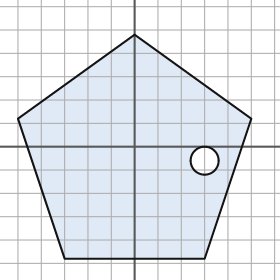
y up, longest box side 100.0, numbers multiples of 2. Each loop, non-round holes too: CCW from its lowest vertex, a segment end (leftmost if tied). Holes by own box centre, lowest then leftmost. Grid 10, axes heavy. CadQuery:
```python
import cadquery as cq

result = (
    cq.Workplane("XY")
    .moveTo(-30.0, -48.0)
    .lineTo(30.0, -48.0)
    .lineTo(50.0, 12.0)
    .lineTo(0.0, 48.0)
    .lineTo(-50.0, 12.0)
    .close()
    .moveTo(30.0, -6.0)
    .circle(6.0)
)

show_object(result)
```